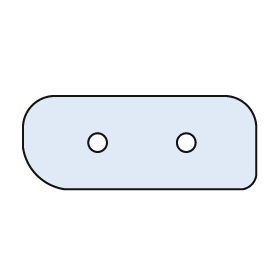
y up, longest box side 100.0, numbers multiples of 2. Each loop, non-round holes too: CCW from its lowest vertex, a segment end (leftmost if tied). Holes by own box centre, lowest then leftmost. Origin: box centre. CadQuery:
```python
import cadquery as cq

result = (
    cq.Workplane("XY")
    .moveTo(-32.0, -20.0)
    .lineTo(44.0, -20.0)
    .threePointArc((48.0, -18.0), (50.0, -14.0))
    .lineTo(50.0, 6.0)
    .threePointArc((46.0, 16.0), (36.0, 20.0))
    .lineTo(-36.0, 20.0)
    .threePointArc((-46.0, 16.0), (-50.0, 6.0))
    .lineTo(-50.0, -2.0)
    .threePointArc((-44.0, -14.0), (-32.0, -20.0))
    .close()
    .moveTo(-18.0, 0.0)
    .circle(4.0)
    .moveTo(20.0, 0.0)
    .circle(4.0)
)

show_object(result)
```